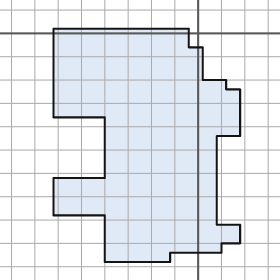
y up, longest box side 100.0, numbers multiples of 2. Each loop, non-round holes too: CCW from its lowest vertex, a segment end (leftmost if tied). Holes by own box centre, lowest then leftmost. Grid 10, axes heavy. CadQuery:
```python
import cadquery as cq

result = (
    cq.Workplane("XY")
    .moveTo(-40.0, -98.0)
    .lineTo(-12.0, -98.0)
    .lineTo(-12.0, -94.0)
    .lineTo(10.0, -94.0)
    .lineTo(10.0, -90.0)
    .lineTo(18.0, -90.0)
    .lineTo(18.0, -82.0)
    .lineTo(8.0, -82.0)
    .lineTo(8.0, -44.0)
    .lineTo(18.0, -44.0)
    .lineTo(18.0, -24.0)
    .lineTo(12.0, -24.0)
    .lineTo(12.0, -20.0)
    .lineTo(2.0, -20.0)
    .lineTo(2.0, -6.0)
    .lineTo(-4.0, -6.0)
    .lineTo(-4.0, 2.0)
    .lineTo(-62.0, 2.0)
    .lineTo(-62.0, -36.0)
    .lineTo(-40.0, -36.0)
    .lineTo(-40.0, -62.0)
    .lineTo(-62.0, -62.0)
    .lineTo(-62.0, -78.0)
    .lineTo(-40.0, -78.0)
    .close()
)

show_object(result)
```